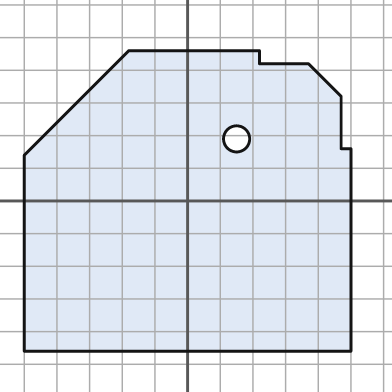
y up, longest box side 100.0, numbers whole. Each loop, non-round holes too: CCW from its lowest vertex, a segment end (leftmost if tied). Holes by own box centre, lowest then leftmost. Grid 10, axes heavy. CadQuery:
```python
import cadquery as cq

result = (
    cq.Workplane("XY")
    .moveTo(-50.0, -46.0)
    .lineTo(50.0, -46.0)
    .lineTo(50.0, 16.0)
    .lineTo(47.0, 16.0)
    .lineTo(47.0, 32.0)
    .lineTo(37.0, 42.0)
    .lineTo(22.0, 42.0)
    .lineTo(22.0, 46.0)
    .lineTo(-18.0, 46.0)
    .lineTo(-50.0, 14.0)
    .close()
    .moveTo(15.0, 19.0)
    .circle(4.0)
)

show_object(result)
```